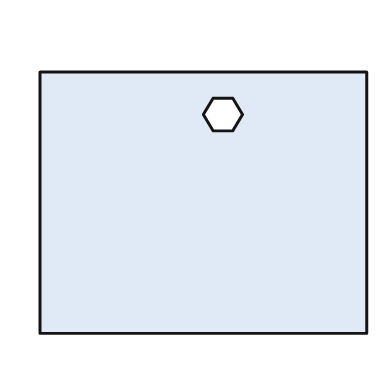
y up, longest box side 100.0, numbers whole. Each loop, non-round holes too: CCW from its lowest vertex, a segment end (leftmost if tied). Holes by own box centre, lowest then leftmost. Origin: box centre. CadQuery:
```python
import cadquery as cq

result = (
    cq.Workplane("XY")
    .moveTo(-50.0, -40.0)
    .lineTo(50.0, -40.0)
    .lineTo(50.0, 40.0)
    .lineTo(-50.0, 40.0)
    .close()
    .moveTo(3.0, 22.0)
    .lineTo(9.0, 22.0)
    .lineTo(12.0, 27.0)
    .lineTo(9.0, 32.0)
    .lineTo(3.0, 32.0)
    .lineTo(0.0, 27.0)
    .close()
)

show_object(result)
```